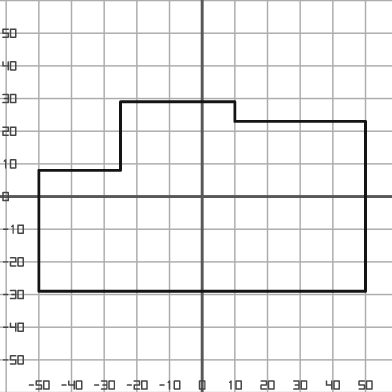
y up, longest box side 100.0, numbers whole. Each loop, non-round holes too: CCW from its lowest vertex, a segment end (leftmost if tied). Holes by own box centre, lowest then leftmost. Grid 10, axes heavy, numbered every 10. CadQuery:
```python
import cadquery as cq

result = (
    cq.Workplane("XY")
    .moveTo(-50.0, -29.0)
    .lineTo(50.0, -29.0)
    .lineTo(50.0, 23.0)
    .lineTo(10.0, 23.0)
    .lineTo(10.0, 29.0)
    .lineTo(-25.0, 29.0)
    .lineTo(-25.0, 8.0)
    .lineTo(-50.0, 8.0)
    .close()
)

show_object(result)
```